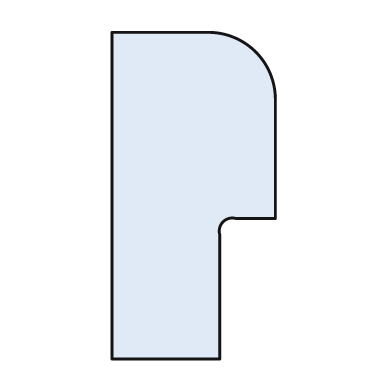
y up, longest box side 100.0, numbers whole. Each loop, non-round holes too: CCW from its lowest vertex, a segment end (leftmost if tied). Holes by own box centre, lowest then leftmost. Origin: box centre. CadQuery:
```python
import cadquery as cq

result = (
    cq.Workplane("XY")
    .moveTo(-25.0, -50.0)
    .lineTo(8.0, -50.0)
    .lineTo(8.0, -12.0)
    .threePointArc((9.0, -8.0), (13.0, -7.0))
    .lineTo(25.0, -7.0)
    .lineTo(25.0, 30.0)
    .threePointArc((19.0, 44.0), (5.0, 50.0))
    .lineTo(-25.0, 50.0)
    .close()
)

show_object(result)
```